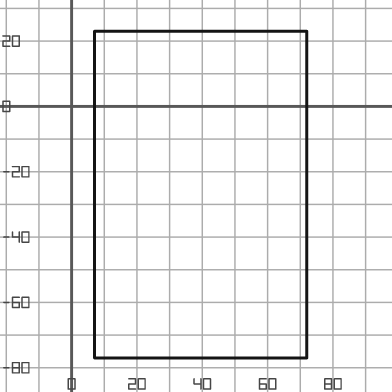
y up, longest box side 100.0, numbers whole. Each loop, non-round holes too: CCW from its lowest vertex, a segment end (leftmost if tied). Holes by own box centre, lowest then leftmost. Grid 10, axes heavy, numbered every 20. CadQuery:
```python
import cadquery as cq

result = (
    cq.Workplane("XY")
    .moveTo(7.0, -77.0)
    .lineTo(72.0, -77.0)
    .lineTo(72.0, 23.0)
    .lineTo(7.0, 23.0)
    .close()
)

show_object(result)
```